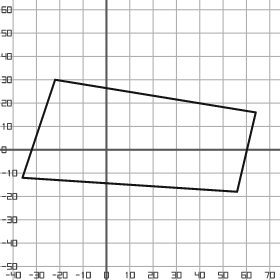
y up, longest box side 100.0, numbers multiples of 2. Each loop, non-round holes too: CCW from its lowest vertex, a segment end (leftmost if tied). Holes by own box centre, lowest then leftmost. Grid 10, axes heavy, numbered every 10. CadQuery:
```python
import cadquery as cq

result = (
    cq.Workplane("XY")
    .moveTo(56.0, -18.0)
    .lineTo(64.0, 16.0)
    .lineTo(-22.0, 30.0)
    .lineTo(-36.0, -12.0)
    .close()
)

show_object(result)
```